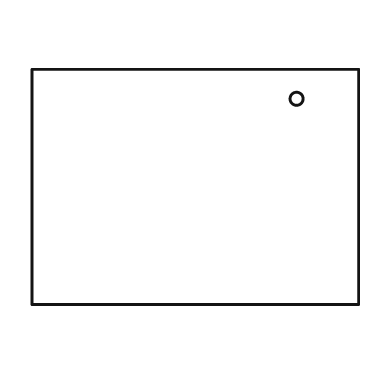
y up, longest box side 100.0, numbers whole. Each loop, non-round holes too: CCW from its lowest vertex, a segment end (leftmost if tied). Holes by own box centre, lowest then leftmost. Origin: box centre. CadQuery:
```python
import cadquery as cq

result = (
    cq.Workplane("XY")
    .moveTo(-50.0, -36.0)
    .lineTo(50.0, -36.0)
    .lineTo(50.0, 36.0)
    .lineTo(-50.0, 36.0)
    .close()
    .moveTo(31.0, 27.0)
    .circle(2.0)
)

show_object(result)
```